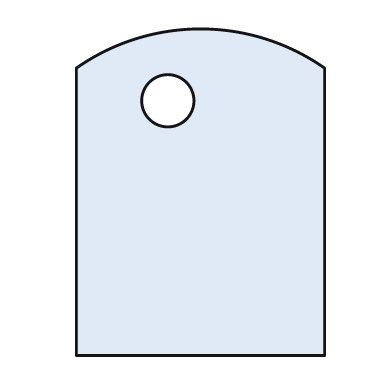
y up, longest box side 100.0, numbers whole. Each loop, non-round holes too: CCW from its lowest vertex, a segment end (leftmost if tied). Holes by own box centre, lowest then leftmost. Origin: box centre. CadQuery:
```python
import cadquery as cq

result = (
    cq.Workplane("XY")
    .moveTo(-38.0, -50.0)
    .lineTo(38.0, -50.0)
    .lineTo(38.0, 38.0)
    .threePointArc((0.0, 50.0), (-38.0, 38.0))
    .close()
    .moveTo(-10.0, 28.0)
    .circle(8.0)
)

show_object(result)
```